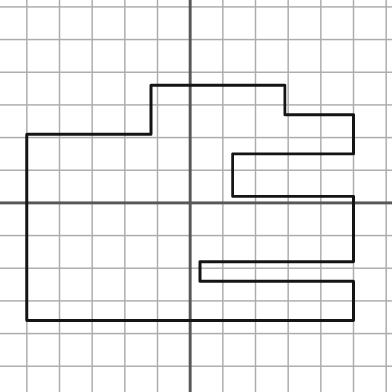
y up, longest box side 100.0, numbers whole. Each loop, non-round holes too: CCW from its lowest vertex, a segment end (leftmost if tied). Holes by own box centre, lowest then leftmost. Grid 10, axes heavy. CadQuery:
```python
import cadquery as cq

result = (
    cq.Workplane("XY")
    .moveTo(-50.0, -36.0)
    .lineTo(50.0, -36.0)
    .lineTo(50.0, -24.0)
    .lineTo(3.0, -24.0)
    .lineTo(3.0, -18.0)
    .lineTo(50.0, -18.0)
    .lineTo(50.0, 2.0)
    .lineTo(13.0, 2.0)
    .lineTo(13.0, 15.0)
    .lineTo(50.0, 15.0)
    .lineTo(50.0, 27.0)
    .lineTo(29.0, 27.0)
    .lineTo(29.0, 36.0)
    .lineTo(-12.0, 36.0)
    .lineTo(-12.0, 21.0)
    .lineTo(-50.0, 21.0)
    .close()
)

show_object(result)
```